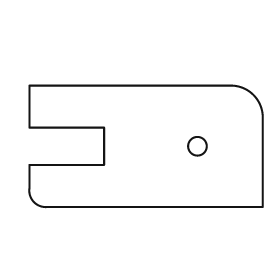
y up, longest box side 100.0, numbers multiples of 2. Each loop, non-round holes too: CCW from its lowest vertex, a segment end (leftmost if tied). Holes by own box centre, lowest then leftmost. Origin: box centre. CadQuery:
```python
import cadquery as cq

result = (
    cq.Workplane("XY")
    .moveTo(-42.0, -26.0)
    .lineTo(50.0, -26.0)
    .lineTo(50.0, 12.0)
    .threePointArc((46.0, 22.0), (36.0, 26.0))
    .lineTo(-50.0, 26.0)
    .lineTo(-50.0, 8.0)
    .lineTo(-18.0, 8.0)
    .lineTo(-18.0, -8.0)
    .lineTo(-50.0, -8.0)
    .lineTo(-50.0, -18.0)
    .threePointArc((-48.0, -24.0), (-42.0, -26.0))
    .close()
    .moveTo(22.0, 0.0)
    .circle(4.0)
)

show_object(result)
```